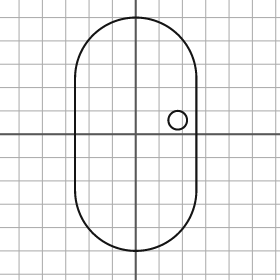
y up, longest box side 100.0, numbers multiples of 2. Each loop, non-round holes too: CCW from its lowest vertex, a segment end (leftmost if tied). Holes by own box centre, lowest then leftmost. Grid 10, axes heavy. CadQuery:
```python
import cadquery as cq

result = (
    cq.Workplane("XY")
    .moveTo(-26.0, -24.0)
    .threePointArc((0.0, -50.0), (26.0, -24.0))
    .lineTo(26.0, 24.0)
    .threePointArc((0.0, 50.0), (-26.0, 24.0))
    .close()
    .moveTo(18.0, 6.0)
    .circle(4.0)
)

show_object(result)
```